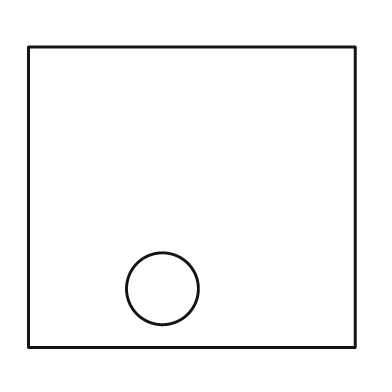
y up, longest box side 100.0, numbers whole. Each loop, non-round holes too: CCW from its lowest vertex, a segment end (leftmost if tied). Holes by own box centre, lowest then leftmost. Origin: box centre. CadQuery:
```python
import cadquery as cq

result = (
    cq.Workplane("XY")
    .moveTo(-50.0, -46.0)
    .lineTo(50.0, -46.0)
    .lineTo(50.0, 46.0)
    .lineTo(-50.0, 46.0)
    .close()
    .moveTo(-9.0, -28.0)
    .circle(11.0)
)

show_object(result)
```